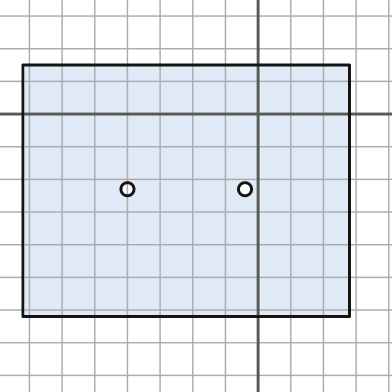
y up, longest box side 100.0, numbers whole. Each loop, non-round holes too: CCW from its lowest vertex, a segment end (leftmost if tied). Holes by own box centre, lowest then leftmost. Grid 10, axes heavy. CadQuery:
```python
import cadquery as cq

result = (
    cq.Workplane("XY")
    .moveTo(-72.0, -62.0)
    .lineTo(28.0, -62.0)
    .lineTo(28.0, 15.0)
    .lineTo(-72.0, 15.0)
    .close()
    .moveTo(-40.0, -23.0)
    .circle(2.0)
    .moveTo(-4.0, -23.0)
    .circle(2.0)
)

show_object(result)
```